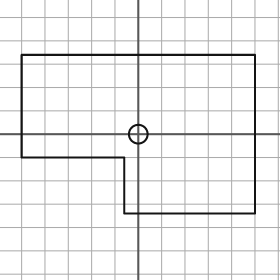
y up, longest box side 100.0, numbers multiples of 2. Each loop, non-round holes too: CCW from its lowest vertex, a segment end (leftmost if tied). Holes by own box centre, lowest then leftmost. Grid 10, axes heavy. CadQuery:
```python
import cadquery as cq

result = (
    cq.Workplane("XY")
    .moveTo(-6.0, -34.0)
    .lineTo(50.0, -34.0)
    .lineTo(50.0, 34.0)
    .lineTo(-50.0, 34.0)
    .lineTo(-50.0, -10.0)
    .lineTo(-6.0, -10.0)
    .close()
    .moveTo(0.0, 0.0)
    .circle(4.0)
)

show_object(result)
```